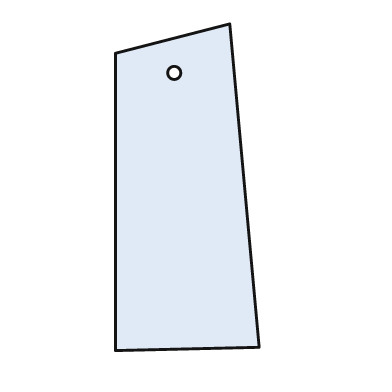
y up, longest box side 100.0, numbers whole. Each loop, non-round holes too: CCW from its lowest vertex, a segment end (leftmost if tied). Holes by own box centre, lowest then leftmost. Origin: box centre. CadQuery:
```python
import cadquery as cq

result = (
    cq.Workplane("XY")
    .moveTo(-22.0, -50.0)
    .lineTo(22.0, -49.0)
    .lineTo(13.0, 50.0)
    .lineTo(-22.0, 41.0)
    .close()
    .moveTo(-4.0, 35.0)
    .circle(2.0)
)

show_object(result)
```